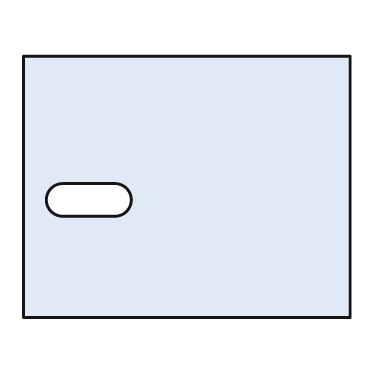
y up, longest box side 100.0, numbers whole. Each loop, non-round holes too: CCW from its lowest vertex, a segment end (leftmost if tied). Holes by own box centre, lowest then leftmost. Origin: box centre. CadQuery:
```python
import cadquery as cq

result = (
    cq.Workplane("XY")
    .moveTo(-50.0, -40.0)
    .lineTo(50.0, -40.0)
    .lineTo(50.0, 40.0)
    .lineTo(-50.0, 40.0)
    .close()
    .moveTo(-38.0, -9.0)
    .lineTo(-22.0, -9.0)
    .threePointArc((-17.0, -4.0), (-22.0, 1.0))
    .lineTo(-38.0, 1.0)
    .threePointArc((-43.0, -4.0), (-38.0, -9.0))
    .close()
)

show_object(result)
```